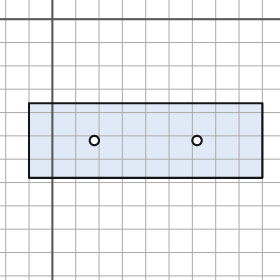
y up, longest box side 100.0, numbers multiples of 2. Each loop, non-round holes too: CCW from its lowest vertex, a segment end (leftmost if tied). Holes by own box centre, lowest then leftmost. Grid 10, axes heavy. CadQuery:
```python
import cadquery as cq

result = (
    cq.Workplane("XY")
    .moveTo(-10.0, -68.0)
    .lineTo(90.0, -68.0)
    .lineTo(90.0, -36.0)
    .lineTo(-10.0, -36.0)
    .close()
    .moveTo(18.0, -52.0)
    .circle(2.0)
    .moveTo(62.0, -52.0)
    .circle(2.0)
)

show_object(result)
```